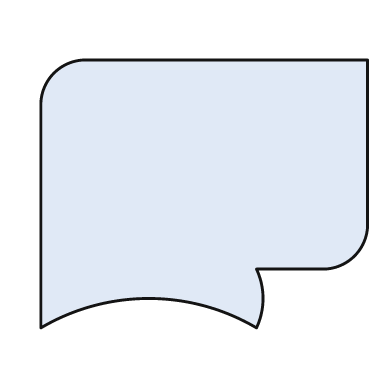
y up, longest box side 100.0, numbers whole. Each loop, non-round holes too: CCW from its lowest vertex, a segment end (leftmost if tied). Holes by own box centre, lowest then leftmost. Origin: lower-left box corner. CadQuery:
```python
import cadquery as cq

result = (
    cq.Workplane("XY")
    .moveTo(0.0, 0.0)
    .threePointArc((33.0, 9.0), (66.0, 0.0))
    .threePointArc((68.0, 9.0), (66.0, 18.0))
    .lineTo(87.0, 18.0)
    .threePointArc((96.0, 22.0), (100.0, 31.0))
    .lineTo(100.0, 82.0)
    .lineTo(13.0, 82.0)
    .threePointArc((4.0, 78.0), (0.0, 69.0))
    .close()
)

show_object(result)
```